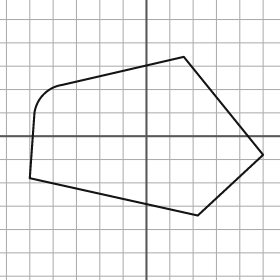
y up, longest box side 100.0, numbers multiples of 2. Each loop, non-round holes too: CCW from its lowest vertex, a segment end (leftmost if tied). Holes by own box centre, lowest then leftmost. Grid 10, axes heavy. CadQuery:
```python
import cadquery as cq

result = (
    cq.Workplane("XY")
    .moveTo(22.0, -34.0)
    .lineTo(50.0, -8.0)
    .lineTo(16.0, 34.0)
    .lineTo(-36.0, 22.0)
    .threePointArc((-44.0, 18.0), (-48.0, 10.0))
    .lineTo(-50.0, -18.0)
    .close()
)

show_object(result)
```